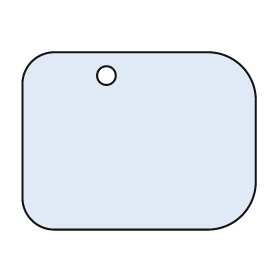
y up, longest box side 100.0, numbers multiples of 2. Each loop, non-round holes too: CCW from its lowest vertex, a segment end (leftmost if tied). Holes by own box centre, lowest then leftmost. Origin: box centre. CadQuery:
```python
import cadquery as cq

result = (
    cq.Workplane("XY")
    .moveTo(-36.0, -38.0)
    .lineTo(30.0, -38.0)
    .threePointArc((44.0, -32.0), (50.0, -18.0))
    .lineTo(50.0, 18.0)
    .threePointArc((44.0, 32.0), (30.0, 38.0))
    .lineTo(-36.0, 38.0)
    .threePointArc((-46.0, 34.0), (-50.0, 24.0))
    .lineTo(-50.0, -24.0)
    .threePointArc((-46.0, -34.0), (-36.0, -38.0))
    .close()
    .moveTo(-14.0, 28.0)
    .circle(4.0)
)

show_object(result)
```